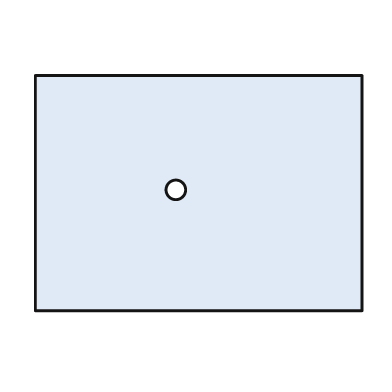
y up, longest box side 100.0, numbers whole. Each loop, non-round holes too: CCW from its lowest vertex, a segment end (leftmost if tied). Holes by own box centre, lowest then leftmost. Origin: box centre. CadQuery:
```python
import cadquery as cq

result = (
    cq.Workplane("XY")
    .moveTo(-50.0, -36.0)
    .lineTo(50.0, -36.0)
    .lineTo(50.0, 36.0)
    .lineTo(-50.0, 36.0)
    .close()
    .moveTo(-7.0, 1.0)
    .circle(3.0)
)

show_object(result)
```